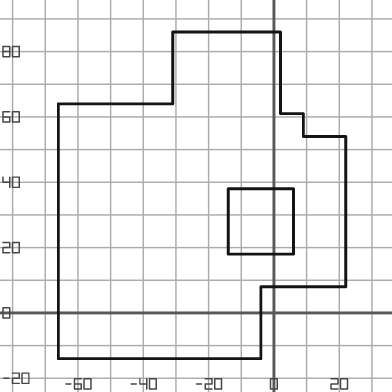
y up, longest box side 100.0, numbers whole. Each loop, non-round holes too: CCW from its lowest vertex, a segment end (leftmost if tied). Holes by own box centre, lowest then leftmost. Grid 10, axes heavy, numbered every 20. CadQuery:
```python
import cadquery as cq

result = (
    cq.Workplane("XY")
    .moveTo(-66.0, -14.0)
    .lineTo(-4.0, -14.0)
    .lineTo(-4.0, 8.0)
    .lineTo(22.0, 8.0)
    .lineTo(22.0, 54.0)
    .lineTo(9.0, 54.0)
    .lineTo(9.0, 61.0)
    .lineTo(2.0, 61.0)
    .lineTo(2.0, 86.0)
    .lineTo(-31.0, 86.0)
    .lineTo(-31.0, 64.0)
    .lineTo(-66.0, 64.0)
    .close()
    .moveTo(-14.0, 18.0)
    .lineTo(6.0, 18.0)
    .lineTo(6.0, 38.0)
    .lineTo(-14.0, 38.0)
    .close()
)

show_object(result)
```